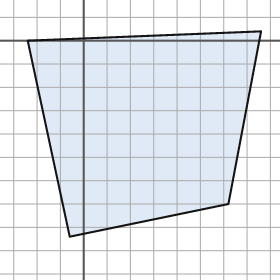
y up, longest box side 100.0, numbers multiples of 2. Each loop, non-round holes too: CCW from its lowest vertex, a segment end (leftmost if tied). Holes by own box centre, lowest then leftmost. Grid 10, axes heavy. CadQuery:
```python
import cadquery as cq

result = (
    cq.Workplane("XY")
    .moveTo(-6.0, -84.0)
    .lineTo(62.0, -70.0)
    .lineTo(76.0, 4.0)
    .lineTo(-24.0, 0.0)
    .close()
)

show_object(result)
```